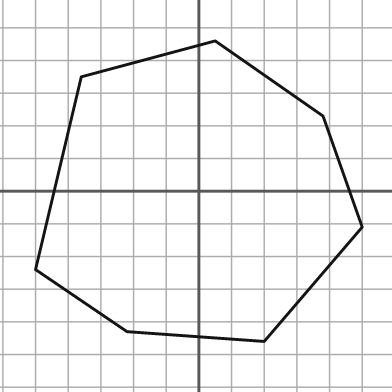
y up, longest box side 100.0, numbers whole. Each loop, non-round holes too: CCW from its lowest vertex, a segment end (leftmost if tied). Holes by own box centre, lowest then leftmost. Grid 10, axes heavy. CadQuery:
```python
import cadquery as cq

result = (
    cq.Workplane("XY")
    .moveTo(20.0, -46.0)
    .lineTo(50.0, -11.0)
    .lineTo(38.0, 23.0)
    .lineTo(5.0, 46.0)
    .lineTo(-36.0, 35.0)
    .lineTo(-50.0, -24.0)
    .lineTo(-22.0, -43.0)
    .close()
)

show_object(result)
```